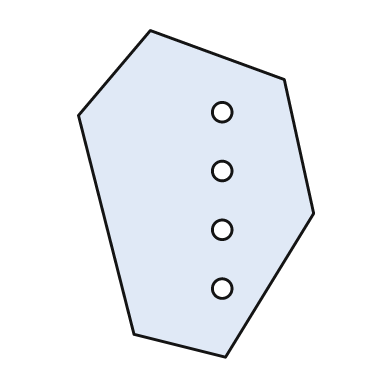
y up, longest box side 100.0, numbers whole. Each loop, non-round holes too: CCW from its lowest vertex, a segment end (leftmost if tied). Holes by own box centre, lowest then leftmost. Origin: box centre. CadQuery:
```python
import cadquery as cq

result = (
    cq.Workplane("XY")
    .moveTo(9.0, -50.0)
    .lineTo(36.0, -6.0)
    .lineTo(27.0, 35.0)
    .lineTo(-14.0, 50.0)
    .lineTo(-36.0, 24.0)
    .lineTo(-19.0, -43.0)
    .close()
    .moveTo(8.0, -29.0)
    .circle(3.0)
    .moveTo(8.0, -11.0)
    .circle(3.0)
    .moveTo(8.0, 7.0)
    .circle(3.0)
    .moveTo(8.0, 25.0)
    .circle(3.0)
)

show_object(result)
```